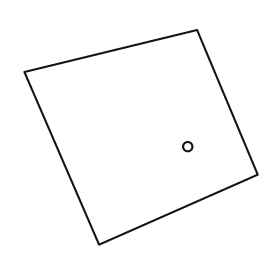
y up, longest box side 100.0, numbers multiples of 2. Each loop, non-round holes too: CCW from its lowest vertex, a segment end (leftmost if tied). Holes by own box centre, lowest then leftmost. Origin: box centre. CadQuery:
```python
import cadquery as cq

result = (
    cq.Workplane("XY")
    .moveTo(-18.0, -46.0)
    .lineTo(50.0, -16.0)
    .lineTo(24.0, 46.0)
    .lineTo(-50.0, 28.0)
    .close()
    .moveTo(20.0, -4.0)
    .circle(2.0)
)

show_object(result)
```